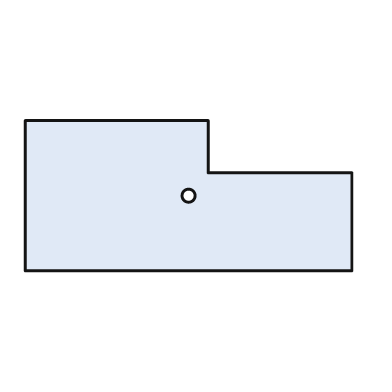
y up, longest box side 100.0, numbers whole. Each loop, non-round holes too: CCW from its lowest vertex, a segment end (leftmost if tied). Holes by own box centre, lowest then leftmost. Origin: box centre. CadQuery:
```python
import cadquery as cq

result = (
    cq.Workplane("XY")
    .moveTo(-50.0, -23.0)
    .lineTo(50.0, -23.0)
    .lineTo(50.0, 7.0)
    .lineTo(6.0, 7.0)
    .lineTo(6.0, 23.0)
    .lineTo(-50.0, 23.0)
    .close()
    .moveTo(0.0, 0.0)
    .circle(2.0)
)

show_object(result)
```